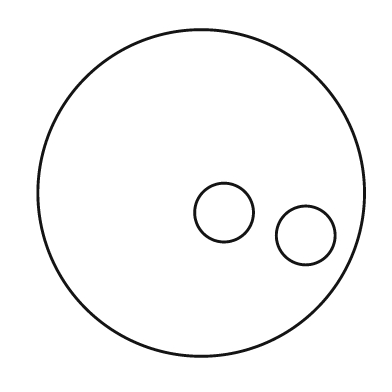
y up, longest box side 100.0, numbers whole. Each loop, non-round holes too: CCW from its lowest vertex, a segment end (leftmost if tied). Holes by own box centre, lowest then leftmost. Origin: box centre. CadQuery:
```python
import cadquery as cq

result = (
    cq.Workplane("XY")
    .moveTo(0.0, 0.0)
    .circle(50.0)
    .moveTo(32.0, -13.0)
    .circle(9.0)
    .moveTo(7.0, -6.0)
    .circle(9.0)
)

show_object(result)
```